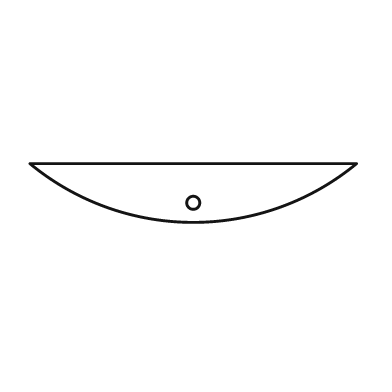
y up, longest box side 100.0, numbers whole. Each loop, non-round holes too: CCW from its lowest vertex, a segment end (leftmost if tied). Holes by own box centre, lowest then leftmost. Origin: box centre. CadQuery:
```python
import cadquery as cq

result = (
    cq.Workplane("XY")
    .moveTo(-50.0, 9.0)
    .threePointArc((0.0, -9.0), (50.0, 9.0))
    .close()
    .moveTo(0.0, -3.0)
    .circle(2.0)
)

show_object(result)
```